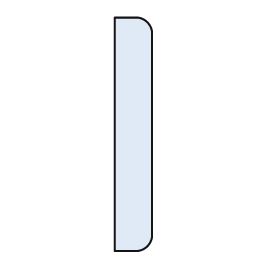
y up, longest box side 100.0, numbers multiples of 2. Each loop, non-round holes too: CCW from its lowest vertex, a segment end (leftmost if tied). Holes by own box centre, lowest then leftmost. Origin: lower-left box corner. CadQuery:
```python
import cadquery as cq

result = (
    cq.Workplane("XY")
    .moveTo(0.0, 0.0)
    .lineTo(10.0, 0.0)
    .threePointArc((14.0, 2.0), (16.0, 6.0))
    .lineTo(16.0, 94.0)
    .threePointArc((14.0, 98.0), (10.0, 100.0))
    .lineTo(0.0, 100.0)
    .close()
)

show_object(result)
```